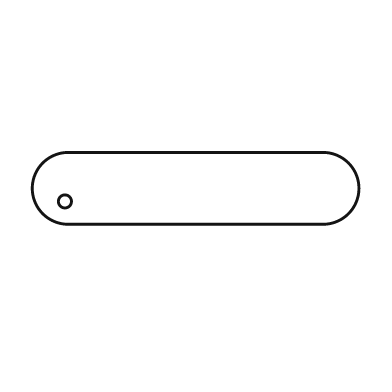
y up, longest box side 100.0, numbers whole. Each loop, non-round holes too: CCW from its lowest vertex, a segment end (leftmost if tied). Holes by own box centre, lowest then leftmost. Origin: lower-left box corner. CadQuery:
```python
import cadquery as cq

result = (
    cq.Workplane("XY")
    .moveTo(11.0, 0.0)
    .lineTo(89.0, 0.0)
    .threePointArc((100.0, 11.0), (89.0, 22.0))
    .lineTo(11.0, 22.0)
    .threePointArc((0.0, 11.0), (11.0, 0.0))
    .close()
    .moveTo(10.0, 7.0)
    .circle(2.0)
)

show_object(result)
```